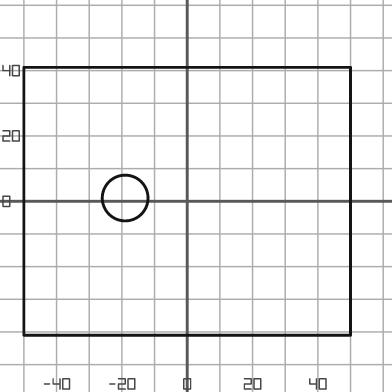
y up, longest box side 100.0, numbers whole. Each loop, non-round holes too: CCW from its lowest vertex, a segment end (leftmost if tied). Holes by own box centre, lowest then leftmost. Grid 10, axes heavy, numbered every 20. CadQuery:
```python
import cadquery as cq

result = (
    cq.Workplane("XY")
    .moveTo(-50.0, -41.0)
    .lineTo(50.0, -41.0)
    .lineTo(50.0, 41.0)
    .lineTo(-50.0, 41.0)
    .close()
    .moveTo(-19.0, 1.0)
    .circle(7.0)
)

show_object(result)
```